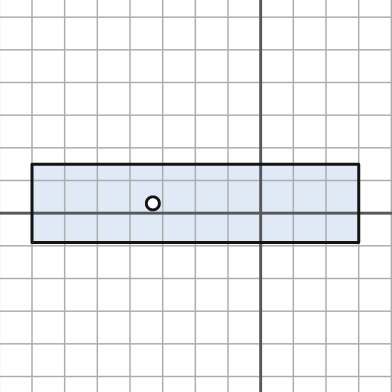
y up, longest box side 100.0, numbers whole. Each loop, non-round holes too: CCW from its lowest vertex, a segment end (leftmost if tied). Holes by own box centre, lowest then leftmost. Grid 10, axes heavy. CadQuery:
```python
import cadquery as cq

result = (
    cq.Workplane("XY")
    .moveTo(-70.0, -9.0)
    .lineTo(30.0, -9.0)
    .lineTo(30.0, 15.0)
    .lineTo(-70.0, 15.0)
    .close()
    .moveTo(-33.0, 3.0)
    .circle(2.0)
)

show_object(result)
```